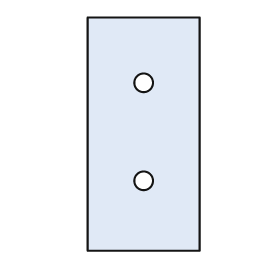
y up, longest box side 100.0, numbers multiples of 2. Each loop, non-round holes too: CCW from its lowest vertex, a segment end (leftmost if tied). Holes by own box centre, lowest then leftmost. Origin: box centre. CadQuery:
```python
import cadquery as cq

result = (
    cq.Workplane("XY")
    .moveTo(-24.0, -50.0)
    .lineTo(24.0, -50.0)
    .lineTo(24.0, 50.0)
    .lineTo(-24.0, 50.0)
    .close()
    .moveTo(0.0, -20.0)
    .circle(4.0)
    .moveTo(0.0, 22.0)
    .circle(4.0)
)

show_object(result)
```